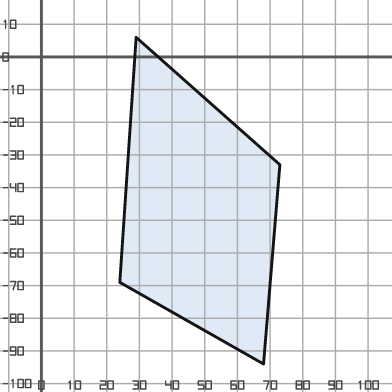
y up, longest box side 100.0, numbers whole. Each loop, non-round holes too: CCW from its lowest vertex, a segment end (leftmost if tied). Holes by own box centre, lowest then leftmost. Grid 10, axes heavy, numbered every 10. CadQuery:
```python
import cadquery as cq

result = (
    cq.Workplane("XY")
    .moveTo(68.0, -94.0)
    .lineTo(73.0, -33.0)
    .lineTo(29.0, 6.0)
    .lineTo(24.0, -69.0)
    .close()
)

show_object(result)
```